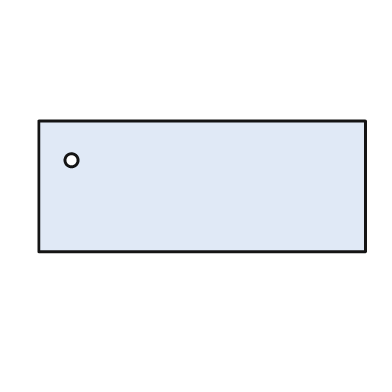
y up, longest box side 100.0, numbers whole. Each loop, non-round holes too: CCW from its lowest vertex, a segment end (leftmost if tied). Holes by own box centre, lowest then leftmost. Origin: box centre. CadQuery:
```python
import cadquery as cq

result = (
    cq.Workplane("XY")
    .moveTo(-50.0, -20.0)
    .lineTo(50.0, -20.0)
    .lineTo(50.0, 20.0)
    .lineTo(-50.0, 20.0)
    .close()
    .moveTo(-40.0, 8.0)
    .circle(2.0)
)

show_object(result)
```